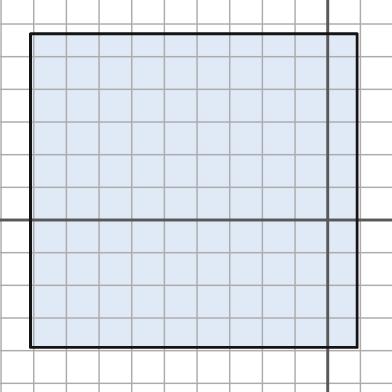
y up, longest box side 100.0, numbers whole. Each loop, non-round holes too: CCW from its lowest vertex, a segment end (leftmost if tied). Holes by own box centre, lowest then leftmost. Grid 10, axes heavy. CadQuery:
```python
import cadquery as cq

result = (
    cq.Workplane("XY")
    .moveTo(-91.0, -39.0)
    .lineTo(9.0, -39.0)
    .lineTo(9.0, 57.0)
    .lineTo(-91.0, 57.0)
    .close()
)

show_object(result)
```